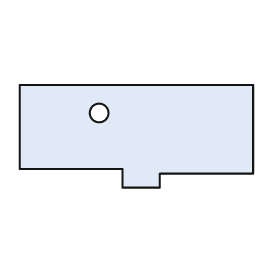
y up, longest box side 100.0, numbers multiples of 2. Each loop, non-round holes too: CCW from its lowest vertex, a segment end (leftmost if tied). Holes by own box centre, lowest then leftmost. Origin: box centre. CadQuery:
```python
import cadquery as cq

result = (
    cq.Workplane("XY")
    .moveTo(-6.0, -22.0)
    .lineTo(10.0, -22.0)
    .lineTo(10.0, -16.0)
    .lineTo(50.0, -16.0)
    .lineTo(50.0, 22.0)
    .lineTo(-50.0, 22.0)
    .lineTo(-50.0, -14.0)
    .lineTo(-6.0, -14.0)
    .close()
    .moveTo(-16.0, 10.0)
    .circle(4.0)
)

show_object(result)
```